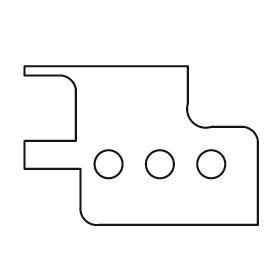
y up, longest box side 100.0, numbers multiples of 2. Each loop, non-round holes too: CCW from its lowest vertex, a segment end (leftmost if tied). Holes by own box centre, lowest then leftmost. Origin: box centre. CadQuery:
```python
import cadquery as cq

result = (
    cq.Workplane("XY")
    .moveTo(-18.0, -34.0)
    .lineTo(50.0, -34.0)
    .lineTo(50.0, 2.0)
    .threePointArc((48.0, 6.0), (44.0, 8.0))
    .lineTo(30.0, 8.0)
    .threePointArc((22.0, 10.0), (20.0, 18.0))
    .lineTo(20.0, 34.0)
    .lineTo(-50.0, 34.0)
    .lineTo(-50.0, 30.0)
    .lineTo(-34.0, 30.0)
    .threePointArc((-30.0, 28.0), (-28.0, 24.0))
    .lineTo(-28.0, 2.0)
    .lineTo(-50.0, 2.0)
    .lineTo(-50.0, -10.0)
    .lineTo(-26.0, -10.0)
    .lineTo(-26.0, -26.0)
    .threePointArc((-24.0, -32.0), (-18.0, -34.0))
    .close()
    .moveTo(-14.0, -8.0)
    .circle(6.0)
    .moveTo(8.0, -8.0)
    .circle(6.0)
    .moveTo(30.0, -8.0)
    .circle(6.0)
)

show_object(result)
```